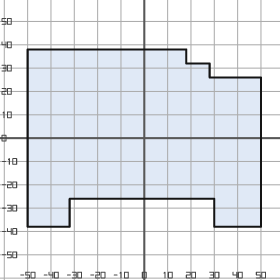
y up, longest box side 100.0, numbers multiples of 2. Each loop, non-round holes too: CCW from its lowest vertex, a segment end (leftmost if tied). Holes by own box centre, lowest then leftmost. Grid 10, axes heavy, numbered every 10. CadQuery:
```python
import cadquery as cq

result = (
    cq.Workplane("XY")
    .moveTo(-50.0, -38.0)
    .lineTo(-32.0, -38.0)
    .lineTo(-32.0, -26.0)
    .lineTo(30.0, -26.0)
    .lineTo(30.0, -38.0)
    .lineTo(50.0, -38.0)
    .lineTo(50.0, 26.0)
    .lineTo(28.0, 26.0)
    .lineTo(28.0, 32.0)
    .lineTo(18.0, 32.0)
    .lineTo(18.0, 38.0)
    .lineTo(-50.0, 38.0)
    .close()
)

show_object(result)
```